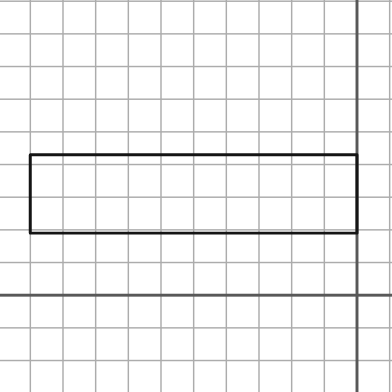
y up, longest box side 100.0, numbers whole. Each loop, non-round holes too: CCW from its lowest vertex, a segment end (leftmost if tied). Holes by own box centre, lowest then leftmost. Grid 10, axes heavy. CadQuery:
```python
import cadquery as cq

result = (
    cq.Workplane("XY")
    .moveTo(-100.0, 19.0)
    .lineTo(0.0, 19.0)
    .lineTo(0.0, 43.0)
    .lineTo(-100.0, 43.0)
    .close()
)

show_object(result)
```